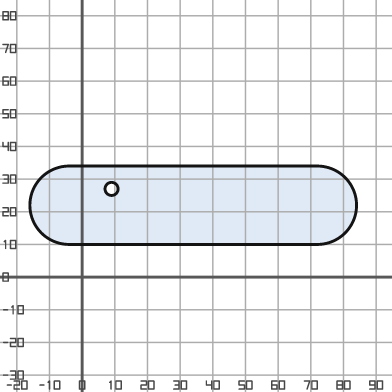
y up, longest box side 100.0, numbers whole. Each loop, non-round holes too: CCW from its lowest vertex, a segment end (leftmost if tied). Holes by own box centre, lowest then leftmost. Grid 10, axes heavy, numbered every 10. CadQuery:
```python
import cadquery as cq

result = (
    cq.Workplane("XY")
    .moveTo(-4.0, 10.0)
    .lineTo(72.0, 10.0)
    .threePointArc((84.0, 22.0), (72.0, 34.0))
    .lineTo(-4.0, 34.0)
    .threePointArc((-16.0, 22.0), (-4.0, 10.0))
    .close()
    .moveTo(9.0, 27.0)
    .circle(2.0)
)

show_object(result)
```